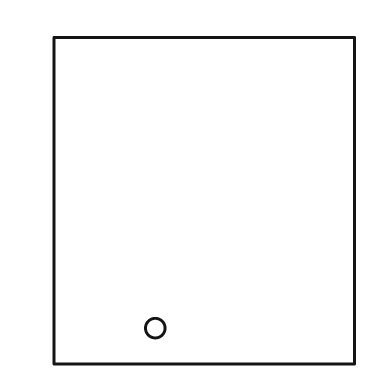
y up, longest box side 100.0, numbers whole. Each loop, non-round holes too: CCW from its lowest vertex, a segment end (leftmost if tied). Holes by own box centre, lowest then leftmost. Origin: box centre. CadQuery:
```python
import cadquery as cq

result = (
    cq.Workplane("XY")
    .moveTo(-46.0, -50.0)
    .lineTo(46.0, -50.0)
    .lineTo(46.0, 50.0)
    .lineTo(-46.0, 50.0)
    .close()
    .moveTo(-15.0, -39.0)
    .circle(3.0)
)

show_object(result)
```